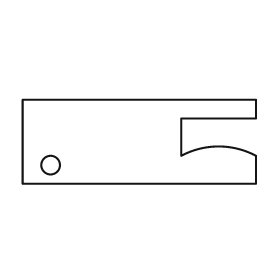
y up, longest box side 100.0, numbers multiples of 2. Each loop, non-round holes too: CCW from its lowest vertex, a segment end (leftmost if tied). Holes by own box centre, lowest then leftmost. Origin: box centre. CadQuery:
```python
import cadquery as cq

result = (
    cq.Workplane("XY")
    .moveTo(-50.0, -18.0)
    .lineTo(50.0, -18.0)
    .lineTo(50.0, -6.0)
    .threePointArc((34.0, -2.0), (18.0, -6.0))
    .lineTo(18.0, 10.0)
    .lineTo(50.0, 10.0)
    .lineTo(50.0, 18.0)
    .lineTo(-50.0, 18.0)
    .close()
    .moveTo(-38.0, -10.0)
    .circle(4.0)
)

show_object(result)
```